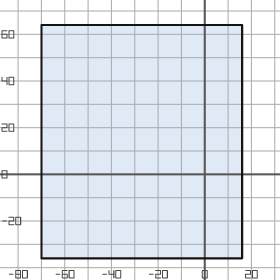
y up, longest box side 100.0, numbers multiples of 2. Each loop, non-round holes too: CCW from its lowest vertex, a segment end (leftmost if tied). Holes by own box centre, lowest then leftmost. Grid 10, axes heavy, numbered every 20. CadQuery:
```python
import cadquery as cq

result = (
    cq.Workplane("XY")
    .moveTo(-70.0, -36.0)
    .lineTo(16.0, -36.0)
    .lineTo(16.0, 64.0)
    .lineTo(-70.0, 64.0)
    .close()
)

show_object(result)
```